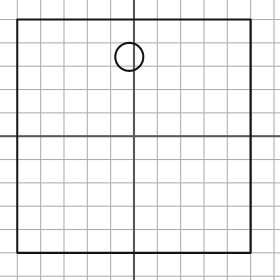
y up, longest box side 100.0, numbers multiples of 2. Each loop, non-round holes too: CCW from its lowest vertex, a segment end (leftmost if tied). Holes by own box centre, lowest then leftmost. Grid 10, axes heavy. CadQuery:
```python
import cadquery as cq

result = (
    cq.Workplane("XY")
    .moveTo(-50.0, -50.0)
    .lineTo(50.0, -50.0)
    .lineTo(50.0, 50.0)
    .lineTo(-50.0, 50.0)
    .close()
    .moveTo(-2.0, 34.0)
    .circle(6.0)
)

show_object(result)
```